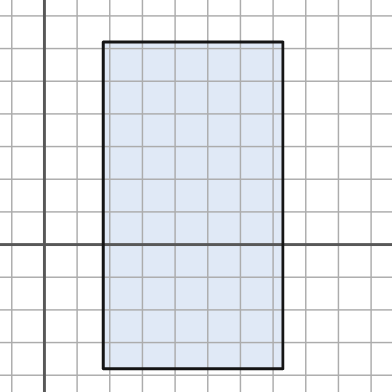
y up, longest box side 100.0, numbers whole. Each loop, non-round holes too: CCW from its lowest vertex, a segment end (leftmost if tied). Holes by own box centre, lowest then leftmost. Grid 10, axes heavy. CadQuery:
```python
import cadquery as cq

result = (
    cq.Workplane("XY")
    .moveTo(18.0, -38.0)
    .lineTo(73.0, -38.0)
    .lineTo(73.0, 62.0)
    .lineTo(18.0, 62.0)
    .close()
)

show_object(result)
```